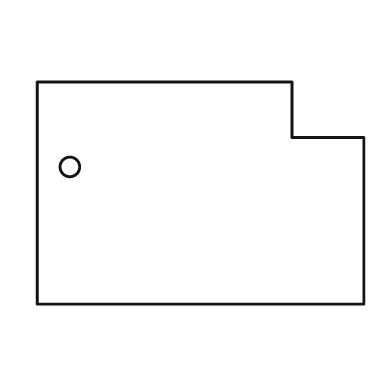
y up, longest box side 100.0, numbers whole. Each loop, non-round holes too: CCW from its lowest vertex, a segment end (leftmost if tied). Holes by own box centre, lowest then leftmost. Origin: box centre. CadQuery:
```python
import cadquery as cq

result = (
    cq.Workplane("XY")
    .moveTo(-50.0, -34.0)
    .lineTo(50.0, -34.0)
    .lineTo(50.0, 17.0)
    .lineTo(28.0, 17.0)
    .lineTo(28.0, 34.0)
    .lineTo(-50.0, 34.0)
    .close()
    .moveTo(-40.0, 8.0)
    .circle(3.0)
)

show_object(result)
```